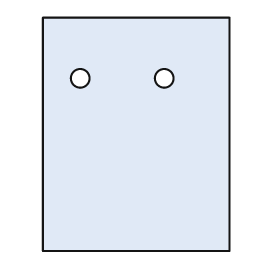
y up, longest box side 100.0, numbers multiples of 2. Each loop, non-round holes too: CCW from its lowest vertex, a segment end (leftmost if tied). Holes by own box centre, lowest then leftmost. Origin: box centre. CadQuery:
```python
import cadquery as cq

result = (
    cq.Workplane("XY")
    .moveTo(-40.0, -50.0)
    .lineTo(40.0, -50.0)
    .lineTo(40.0, 50.0)
    .lineTo(-40.0, 50.0)
    .close()
    .moveTo(-24.0, 24.0)
    .circle(4.0)
    .moveTo(12.0, 24.0)
    .circle(4.0)
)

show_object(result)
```